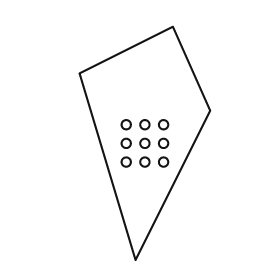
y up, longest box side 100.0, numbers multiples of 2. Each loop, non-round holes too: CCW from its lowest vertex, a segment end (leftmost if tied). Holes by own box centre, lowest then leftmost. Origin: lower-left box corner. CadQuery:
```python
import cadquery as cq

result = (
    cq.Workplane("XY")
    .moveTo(24.0, 0.0)
    .lineTo(56.0, 64.0)
    .lineTo(40.0, 100.0)
    .lineTo(0.0, 80.0)
    .close()
    .moveTo(20.0, 42.0)
    .circle(2.0)
    .moveTo(28.0, 42.0)
    .circle(2.0)
    .moveTo(36.0, 42.0)
    .circle(2.0)
    .moveTo(20.0, 50.0)
    .circle(2.0)
    .moveTo(28.0, 50.0)
    .circle(2.0)
    .moveTo(36.0, 50.0)
    .circle(2.0)
    .moveTo(20.0, 58.0)
    .circle(2.0)
    .moveTo(28.0, 58.0)
    .circle(2.0)
    .moveTo(36.0, 58.0)
    .circle(2.0)
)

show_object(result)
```